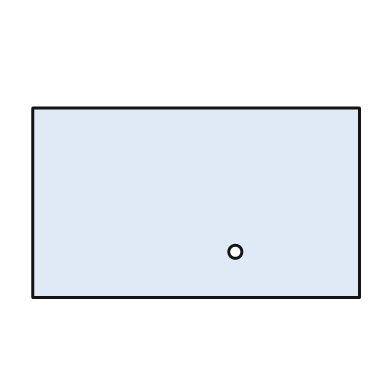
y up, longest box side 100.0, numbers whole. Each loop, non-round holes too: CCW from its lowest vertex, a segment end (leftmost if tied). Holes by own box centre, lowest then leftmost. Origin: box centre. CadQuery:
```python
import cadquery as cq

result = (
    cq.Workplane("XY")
    .moveTo(-50.0, -29.0)
    .lineTo(50.0, -29.0)
    .lineTo(50.0, 29.0)
    .lineTo(-50.0, 29.0)
    .close()
    .moveTo(12.0, -15.0)
    .circle(2.0)
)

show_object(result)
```